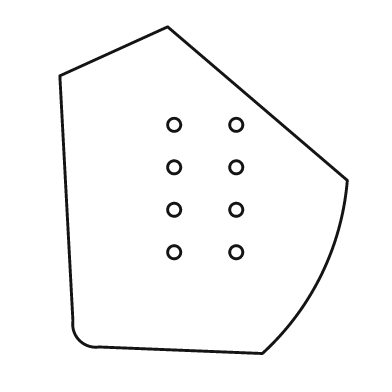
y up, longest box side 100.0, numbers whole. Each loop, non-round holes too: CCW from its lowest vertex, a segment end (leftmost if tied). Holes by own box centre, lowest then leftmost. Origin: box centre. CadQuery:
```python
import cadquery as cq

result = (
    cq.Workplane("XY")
    .moveTo(18.0, -50.0)
    .threePointArc((36.0, -26.0), (44.0, 3.0))
    .lineTo(-11.0, 50.0)
    .lineTo(-44.0, 35.0)
    .lineTo(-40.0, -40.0)
    .threePointArc((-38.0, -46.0), (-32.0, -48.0))
    .close()
    .moveTo(-9.0, -19.0)
    .circle(2.0)
    .moveTo(10.0, -19.0)
    .circle(2.0)
    .moveTo(-9.0, -6.0)
    .circle(2.0)
    .moveTo(10.0, -6.0)
    .circle(2.0)
    .moveTo(-9.0, 7.0)
    .circle(2.0)
    .moveTo(10.0, 7.0)
    .circle(2.0)
    .moveTo(-9.0, 20.0)
    .circle(2.0)
    .moveTo(10.0, 20.0)
    .circle(2.0)
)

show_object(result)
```